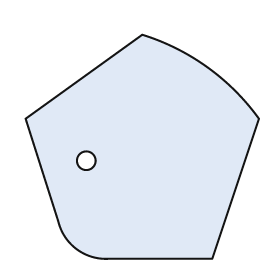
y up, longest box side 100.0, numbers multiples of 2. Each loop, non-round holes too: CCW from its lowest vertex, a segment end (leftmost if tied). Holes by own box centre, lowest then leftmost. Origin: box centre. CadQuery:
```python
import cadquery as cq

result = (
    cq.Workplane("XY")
    .moveTo(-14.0, -48.0)
    .lineTo(30.0, -48.0)
    .lineTo(50.0, 12.0)
    .threePointArc((28.0, 34.0), (0.0, 48.0))
    .lineTo(-50.0, 12.0)
    .lineTo(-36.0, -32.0)
    .threePointArc((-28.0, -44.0), (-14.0, -48.0))
    .close()
    .moveTo(-24.0, -6.0)
    .circle(4.0)
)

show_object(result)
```